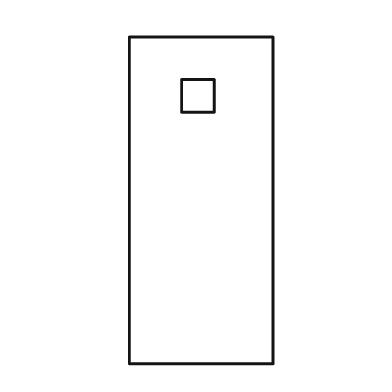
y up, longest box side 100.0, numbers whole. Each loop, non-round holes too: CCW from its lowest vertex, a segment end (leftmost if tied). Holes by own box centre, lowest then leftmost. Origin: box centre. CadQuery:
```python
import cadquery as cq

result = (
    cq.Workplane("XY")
    .moveTo(-22.0, -50.0)
    .lineTo(22.0, -50.0)
    .lineTo(22.0, 50.0)
    .lineTo(-22.0, 50.0)
    .close()
    .moveTo(-6.0, 27.0)
    .lineTo(4.0, 27.0)
    .lineTo(4.0, 37.0)
    .lineTo(-6.0, 37.0)
    .close()
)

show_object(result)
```